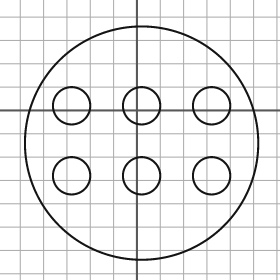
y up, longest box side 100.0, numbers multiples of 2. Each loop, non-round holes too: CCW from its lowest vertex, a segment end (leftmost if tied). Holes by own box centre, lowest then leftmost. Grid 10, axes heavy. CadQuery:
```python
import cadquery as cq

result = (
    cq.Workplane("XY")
    .moveTo(2.0, -14.0)
    .circle(50.0)
    .moveTo(-28.0, -28.0)
    .circle(8.0)
    .moveTo(2.0, -28.0)
    .circle(8.0)
    .moveTo(32.0, -28.0)
    .circle(8.0)
    .moveTo(-28.0, 2.0)
    .circle(8.0)
    .moveTo(2.0, 2.0)
    .circle(8.0)
    .moveTo(32.0, 2.0)
    .circle(8.0)
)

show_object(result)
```